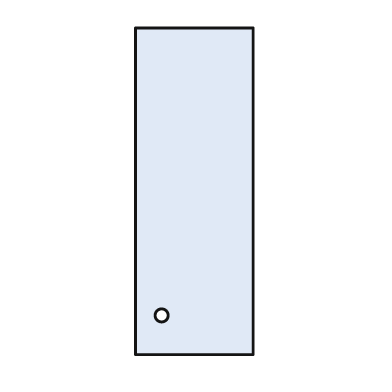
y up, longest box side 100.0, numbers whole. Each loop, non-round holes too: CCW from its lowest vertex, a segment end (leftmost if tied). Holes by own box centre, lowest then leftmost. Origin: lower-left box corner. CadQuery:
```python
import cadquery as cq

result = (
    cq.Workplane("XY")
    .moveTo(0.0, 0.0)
    .lineTo(36.0, 0.0)
    .lineTo(36.0, 100.0)
    .lineTo(0.0, 100.0)
    .close()
    .moveTo(8.0, 12.0)
    .circle(2.0)
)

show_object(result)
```